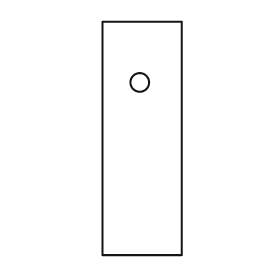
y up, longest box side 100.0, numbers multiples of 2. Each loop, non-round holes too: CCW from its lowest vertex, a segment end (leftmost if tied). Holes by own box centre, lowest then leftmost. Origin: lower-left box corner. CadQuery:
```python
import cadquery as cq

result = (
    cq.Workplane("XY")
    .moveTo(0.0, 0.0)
    .lineTo(34.0, 0.0)
    .lineTo(34.0, 100.0)
    .lineTo(0.0, 100.0)
    .close()
    .moveTo(16.0, 74.0)
    .circle(4.0)
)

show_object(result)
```